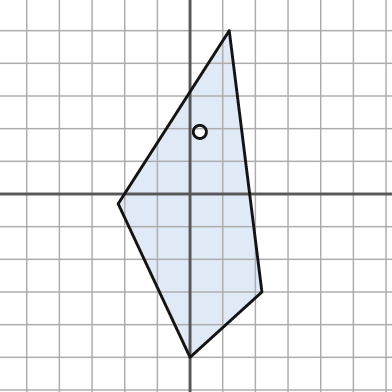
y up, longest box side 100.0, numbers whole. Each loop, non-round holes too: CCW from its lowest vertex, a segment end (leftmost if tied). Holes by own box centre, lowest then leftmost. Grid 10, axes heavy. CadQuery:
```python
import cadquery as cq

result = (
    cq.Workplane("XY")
    .moveTo(0.0, -50.0)
    .lineTo(22.0, -30.0)
    .lineTo(12.0, 50.0)
    .lineTo(-22.0, -3.0)
    .close()
    .moveTo(3.0, 19.0)
    .circle(2.0)
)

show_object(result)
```